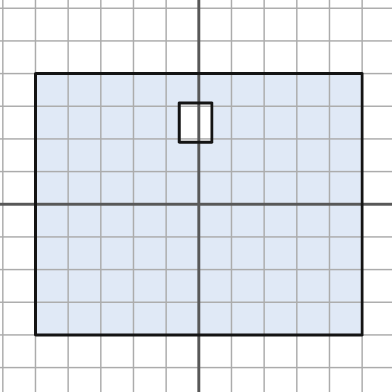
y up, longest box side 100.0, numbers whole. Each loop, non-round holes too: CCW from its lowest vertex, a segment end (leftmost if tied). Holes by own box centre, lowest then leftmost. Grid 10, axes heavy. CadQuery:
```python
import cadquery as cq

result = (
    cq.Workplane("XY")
    .moveTo(-50.0, -40.0)
    .lineTo(50.0, -40.0)
    .lineTo(50.0, 40.0)
    .lineTo(-50.0, 40.0)
    .close()
    .moveTo(-6.0, 19.0)
    .lineTo(4.0, 19.0)
    .lineTo(4.0, 31.0)
    .lineTo(-6.0, 31.0)
    .close()
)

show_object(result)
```